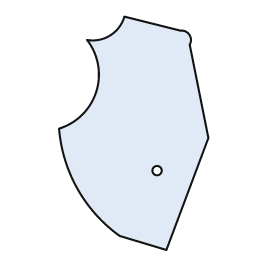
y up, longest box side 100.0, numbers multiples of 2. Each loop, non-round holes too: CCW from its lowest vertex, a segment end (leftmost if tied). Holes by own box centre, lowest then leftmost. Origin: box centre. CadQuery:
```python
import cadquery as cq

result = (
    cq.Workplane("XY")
    .moveTo(14.0, -50.0)
    .lineTo(32.0, -2.0)
    .lineTo(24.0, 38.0)
    .threePointArc((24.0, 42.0), (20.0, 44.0))
    .lineTo(-4.0, 50.0)
    .threePointArc((-10.0, 42.0), (-20.0, 40.0))
    .threePointArc((-16.0, 18.0), (-32.0, 2.0))
    .threePointArc((-24.0, -24.0), (-6.0, -44.0))
    .close()
    .moveTo(10.0, -16.0)
    .circle(2.0)
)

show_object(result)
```